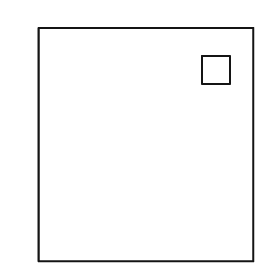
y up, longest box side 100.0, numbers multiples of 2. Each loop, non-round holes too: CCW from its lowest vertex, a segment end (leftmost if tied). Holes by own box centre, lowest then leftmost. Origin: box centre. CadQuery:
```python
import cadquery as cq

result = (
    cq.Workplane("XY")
    .moveTo(-46.0, -50.0)
    .lineTo(46.0, -50.0)
    .lineTo(46.0, 50.0)
    .lineTo(-46.0, 50.0)
    .close()
    .moveTo(24.0, 26.0)
    .lineTo(36.0, 26.0)
    .lineTo(36.0, 38.0)
    .lineTo(24.0, 38.0)
    .close()
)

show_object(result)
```